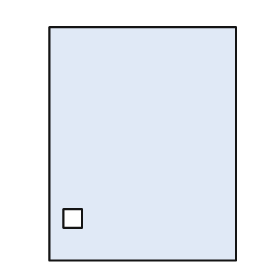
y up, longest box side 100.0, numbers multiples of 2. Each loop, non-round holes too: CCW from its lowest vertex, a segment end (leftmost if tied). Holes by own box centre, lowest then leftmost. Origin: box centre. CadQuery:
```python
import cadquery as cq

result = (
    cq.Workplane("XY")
    .moveTo(-40.0, -50.0)
    .lineTo(40.0, -50.0)
    .lineTo(40.0, 50.0)
    .lineTo(-40.0, 50.0)
    .close()
    .moveTo(-34.0, -36.0)
    .lineTo(-26.0, -36.0)
    .lineTo(-26.0, -28.0)
    .lineTo(-34.0, -28.0)
    .close()
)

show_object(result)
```